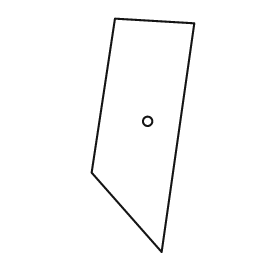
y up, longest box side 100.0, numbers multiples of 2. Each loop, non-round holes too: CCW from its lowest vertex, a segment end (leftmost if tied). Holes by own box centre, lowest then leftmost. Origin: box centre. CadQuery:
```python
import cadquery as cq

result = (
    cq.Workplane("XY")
    .moveTo(8.0, -50.0)
    .lineTo(22.0, 48.0)
    .lineTo(-12.0, 50.0)
    .lineTo(-22.0, -16.0)
    .close()
    .moveTo(2.0, 6.0)
    .circle(2.0)
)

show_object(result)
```